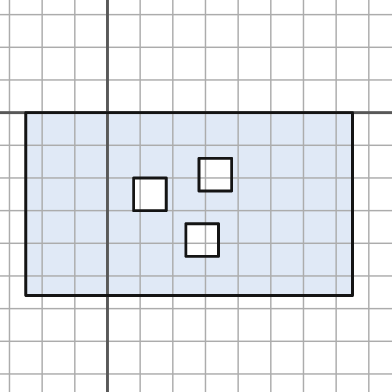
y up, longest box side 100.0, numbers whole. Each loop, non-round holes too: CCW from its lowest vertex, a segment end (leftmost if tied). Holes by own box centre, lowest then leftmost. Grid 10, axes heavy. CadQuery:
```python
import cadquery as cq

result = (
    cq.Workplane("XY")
    .moveTo(-25.0, -56.0)
    .lineTo(75.0, -56.0)
    .lineTo(75.0, 0.0)
    .lineTo(-25.0, 0.0)
    .close()
    .moveTo(24.0, -44.0)
    .lineTo(34.0, -44.0)
    .lineTo(34.0, -34.0)
    .lineTo(24.0, -34.0)
    .close()
    .moveTo(8.0, -30.0)
    .lineTo(18.0, -30.0)
    .lineTo(18.0, -20.0)
    .lineTo(8.0, -20.0)
    .close()
    .moveTo(28.0, -24.0)
    .lineTo(38.0, -24.0)
    .lineTo(38.0, -14.0)
    .lineTo(28.0, -14.0)
    .close()
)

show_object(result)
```